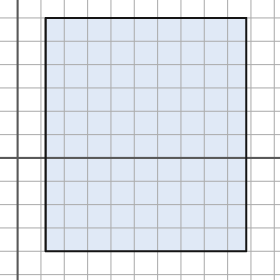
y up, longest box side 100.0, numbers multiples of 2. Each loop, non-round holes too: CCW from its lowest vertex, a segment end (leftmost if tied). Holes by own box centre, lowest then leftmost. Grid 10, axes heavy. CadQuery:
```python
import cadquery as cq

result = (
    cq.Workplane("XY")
    .moveTo(12.0, -40.0)
    .lineTo(98.0, -40.0)
    .lineTo(98.0, 60.0)
    .lineTo(12.0, 60.0)
    .close()
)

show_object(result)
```